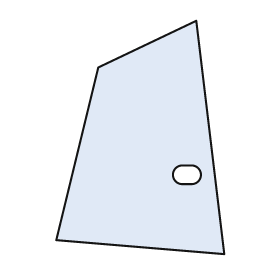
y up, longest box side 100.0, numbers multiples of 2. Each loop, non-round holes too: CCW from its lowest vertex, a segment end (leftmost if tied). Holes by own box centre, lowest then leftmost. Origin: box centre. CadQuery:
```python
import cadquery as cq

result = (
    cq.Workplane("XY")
    .moveTo(36.0, -50.0)
    .lineTo(24.0, 50.0)
    .lineTo(-18.0, 30.0)
    .lineTo(-36.0, -44.0)
    .close()
    .moveTo(18.0, -20.0)
    .lineTo(22.0, -20.0)
    .threePointArc((26.0, -16.0), (22.0, -12.0))
    .lineTo(18.0, -12.0)
    .threePointArc((14.0, -16.0), (18.0, -20.0))
    .close()
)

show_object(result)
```